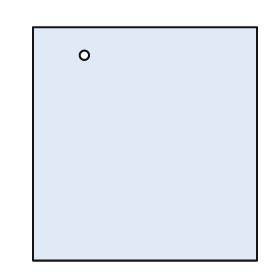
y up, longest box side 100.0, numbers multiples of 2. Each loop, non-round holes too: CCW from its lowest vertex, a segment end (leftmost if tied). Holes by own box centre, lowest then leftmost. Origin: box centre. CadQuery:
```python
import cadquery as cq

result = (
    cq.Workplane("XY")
    .moveTo(-48.0, -50.0)
    .lineTo(48.0, -50.0)
    .lineTo(48.0, 50.0)
    .lineTo(-48.0, 50.0)
    .close()
    .moveTo(-26.0, 38.0)
    .circle(2.0)
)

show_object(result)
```